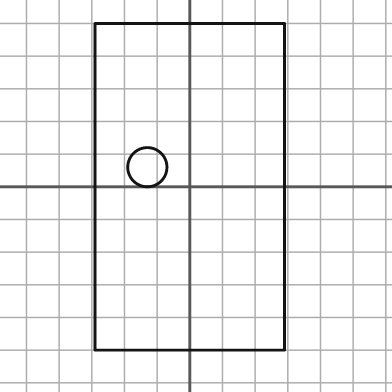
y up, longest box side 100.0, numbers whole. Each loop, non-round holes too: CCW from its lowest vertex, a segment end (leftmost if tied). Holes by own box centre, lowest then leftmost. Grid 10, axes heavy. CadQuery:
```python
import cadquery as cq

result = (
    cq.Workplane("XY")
    .moveTo(-29.0, -50.0)
    .lineTo(29.0, -50.0)
    .lineTo(29.0, 50.0)
    .lineTo(-29.0, 50.0)
    .close()
    .moveTo(-13.0, 6.0)
    .circle(6.0)
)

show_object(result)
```